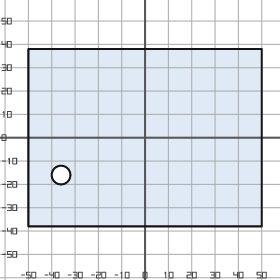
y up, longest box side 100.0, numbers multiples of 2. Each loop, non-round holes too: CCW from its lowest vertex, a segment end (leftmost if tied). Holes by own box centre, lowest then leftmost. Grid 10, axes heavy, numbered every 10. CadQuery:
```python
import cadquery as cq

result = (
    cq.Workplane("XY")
    .moveTo(-50.0, -38.0)
    .lineTo(50.0, -38.0)
    .lineTo(50.0, 38.0)
    .lineTo(-50.0, 38.0)
    .close()
    .moveTo(-36.0, -16.0)
    .circle(4.0)
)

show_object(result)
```